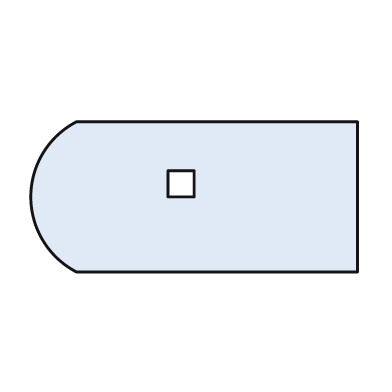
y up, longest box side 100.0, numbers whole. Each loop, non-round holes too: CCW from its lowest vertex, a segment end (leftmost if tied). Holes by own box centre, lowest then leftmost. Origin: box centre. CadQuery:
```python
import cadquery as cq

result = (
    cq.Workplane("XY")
    .moveTo(-36.0, -23.0)
    .lineTo(50.0, -23.0)
    .lineTo(50.0, 23.0)
    .lineTo(-36.0, 23.0)
    .threePointArc((-50.0, 0.0), (-36.0, -23.0))
    .close()
    .moveTo(-8.0, 0.0)
    .lineTo(0.0, 0.0)
    .lineTo(0.0, 8.0)
    .lineTo(-8.0, 8.0)
    .close()
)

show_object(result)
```